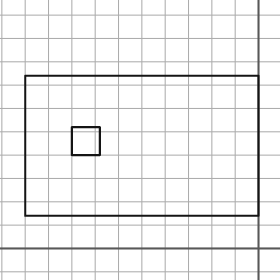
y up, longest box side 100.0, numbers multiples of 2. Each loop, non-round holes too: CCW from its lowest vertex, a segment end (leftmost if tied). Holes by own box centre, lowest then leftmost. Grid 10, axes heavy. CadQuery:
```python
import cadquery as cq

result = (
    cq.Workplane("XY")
    .moveTo(-100.0, 14.0)
    .lineTo(0.0, 14.0)
    .lineTo(0.0, 74.0)
    .lineTo(-100.0, 74.0)
    .close()
    .moveTo(-80.0, 40.0)
    .lineTo(-68.0, 40.0)
    .lineTo(-68.0, 52.0)
    .lineTo(-80.0, 52.0)
    .close()
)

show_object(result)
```